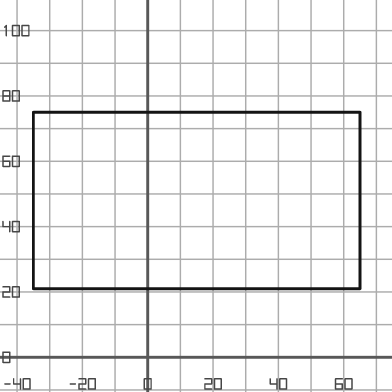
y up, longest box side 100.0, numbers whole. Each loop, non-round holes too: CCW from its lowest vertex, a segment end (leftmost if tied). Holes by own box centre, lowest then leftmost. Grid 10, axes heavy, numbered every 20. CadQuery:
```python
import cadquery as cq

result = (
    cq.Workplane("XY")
    .moveTo(-35.0, 21.0)
    .lineTo(65.0, 21.0)
    .lineTo(65.0, 75.0)
    .lineTo(-35.0, 75.0)
    .close()
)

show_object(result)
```